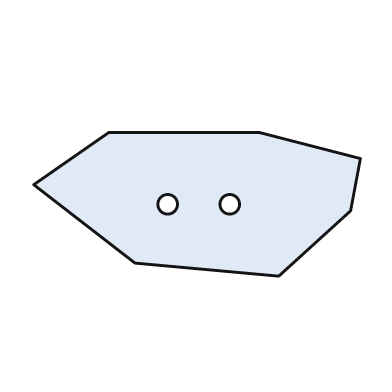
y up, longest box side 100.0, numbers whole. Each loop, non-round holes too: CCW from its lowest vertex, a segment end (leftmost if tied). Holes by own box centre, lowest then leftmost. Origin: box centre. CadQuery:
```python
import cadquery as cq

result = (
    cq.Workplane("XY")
    .moveTo(25.0, -22.0)
    .lineTo(47.0, -2.0)
    .lineTo(50.0, 14.0)
    .lineTo(19.0, 22.0)
    .lineTo(-27.0, 22.0)
    .lineTo(-50.0, 6.0)
    .lineTo(-19.0, -18.0)
    .close()
    .moveTo(-9.0, 0.0)
    .circle(3.0)
    .moveTo(10.0, 0.0)
    .circle(3.0)
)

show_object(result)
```